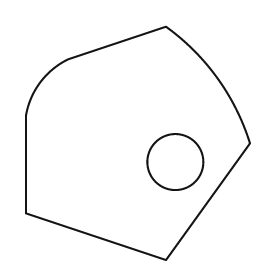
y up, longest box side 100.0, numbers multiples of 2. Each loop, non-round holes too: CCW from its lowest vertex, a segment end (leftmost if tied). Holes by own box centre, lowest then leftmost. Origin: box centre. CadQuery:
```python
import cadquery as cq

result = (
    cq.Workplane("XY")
    .moveTo(12.0, -50.0)
    .lineTo(48.0, 0.0)
    .threePointArc((34.0, 28.0), (12.0, 50.0))
    .lineTo(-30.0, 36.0)
    .threePointArc((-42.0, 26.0), (-48.0, 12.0))
    .lineTo(-48.0, -30.0)
    .close()
    .moveTo(16.0, -8.0)
    .circle(12.0)
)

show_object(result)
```